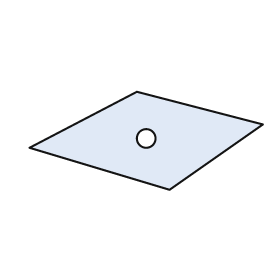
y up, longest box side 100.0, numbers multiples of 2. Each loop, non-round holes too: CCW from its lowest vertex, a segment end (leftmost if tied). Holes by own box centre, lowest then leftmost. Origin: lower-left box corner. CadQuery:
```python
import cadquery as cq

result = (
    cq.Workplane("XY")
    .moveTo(60.0, 0.0)
    .lineTo(100.0, 28.0)
    .lineTo(46.0, 42.0)
    .lineTo(0.0, 18.0)
    .close()
    .moveTo(50.0, 22.0)
    .circle(4.0)
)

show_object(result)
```